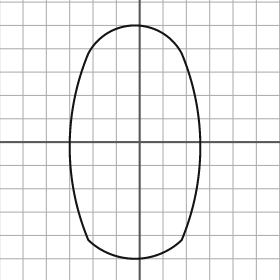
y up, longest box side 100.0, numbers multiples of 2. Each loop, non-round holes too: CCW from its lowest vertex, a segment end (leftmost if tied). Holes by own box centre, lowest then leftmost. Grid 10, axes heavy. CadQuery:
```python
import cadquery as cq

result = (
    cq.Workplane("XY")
    .moveTo(-22.0, -42.0)
    .threePointArc((-2.0, -50.0), (18.0, -42.0))
    .threePointArc((26.0, -2.0), (18.0, 38.0))
    .threePointArc((-2.0, 50.0), (-22.0, 38.0))
    .threePointArc((-30.0, -2.0), (-22.0, -42.0))
    .close()
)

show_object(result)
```